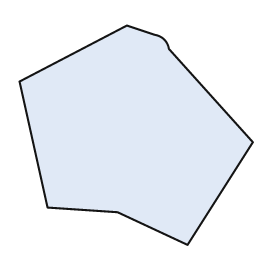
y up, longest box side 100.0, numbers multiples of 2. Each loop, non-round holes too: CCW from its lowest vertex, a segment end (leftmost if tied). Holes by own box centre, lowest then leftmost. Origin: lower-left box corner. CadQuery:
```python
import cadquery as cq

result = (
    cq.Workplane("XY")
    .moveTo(72.0, 0.0)
    .lineTo(100.0, 44.0)
    .lineTo(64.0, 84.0)
    .threePointArc((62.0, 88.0), (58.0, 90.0))
    .lineTo(46.0, 94.0)
    .lineTo(0.0, 70.0)
    .lineTo(12.0, 16.0)
    .lineTo(42.0, 14.0)
    .close()
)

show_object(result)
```